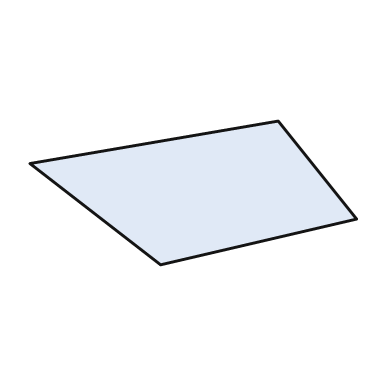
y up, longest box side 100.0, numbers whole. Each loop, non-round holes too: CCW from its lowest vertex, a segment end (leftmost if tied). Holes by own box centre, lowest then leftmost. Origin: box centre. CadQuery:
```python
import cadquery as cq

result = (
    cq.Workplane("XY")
    .moveTo(-10.0, -22.0)
    .lineTo(50.0, -8.0)
    .lineTo(26.0, 22.0)
    .lineTo(-50.0, 9.0)
    .close()
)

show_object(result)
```